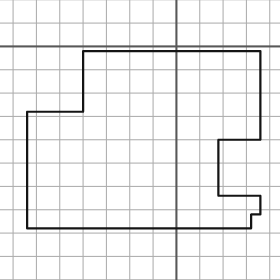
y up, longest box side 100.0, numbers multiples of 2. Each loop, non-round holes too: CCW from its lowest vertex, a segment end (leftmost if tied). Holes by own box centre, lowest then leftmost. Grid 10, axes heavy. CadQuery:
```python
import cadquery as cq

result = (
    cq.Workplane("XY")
    .moveTo(-64.0, -78.0)
    .lineTo(32.0, -78.0)
    .lineTo(32.0, -72.0)
    .lineTo(36.0, -72.0)
    .lineTo(36.0, -64.0)
    .lineTo(18.0, -64.0)
    .lineTo(18.0, -40.0)
    .lineTo(36.0, -40.0)
    .lineTo(36.0, -2.0)
    .lineTo(-40.0, -2.0)
    .lineTo(-40.0, -28.0)
    .lineTo(-64.0, -28.0)
    .close()
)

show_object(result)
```